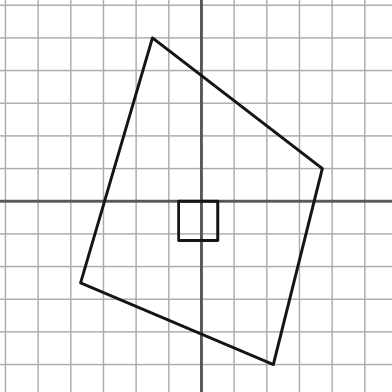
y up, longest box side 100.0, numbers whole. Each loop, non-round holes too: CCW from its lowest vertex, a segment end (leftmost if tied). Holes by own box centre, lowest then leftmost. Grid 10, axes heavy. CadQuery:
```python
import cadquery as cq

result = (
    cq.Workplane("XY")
    .moveTo(22.0, -50.0)
    .lineTo(37.0, 10.0)
    .lineTo(-15.0, 50.0)
    .lineTo(-37.0, -25.0)
    .close()
    .moveTo(-7.0, -12.0)
    .lineTo(5.0, -12.0)
    .lineTo(5.0, 0.0)
    .lineTo(-7.0, 0.0)
    .close()
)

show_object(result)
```